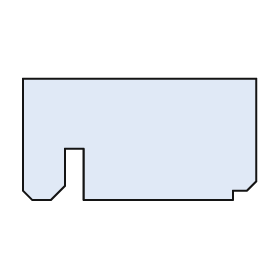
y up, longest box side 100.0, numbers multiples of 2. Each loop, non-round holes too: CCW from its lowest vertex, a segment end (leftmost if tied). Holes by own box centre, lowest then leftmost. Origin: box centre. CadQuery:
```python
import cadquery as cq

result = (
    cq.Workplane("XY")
    .moveTo(-46.0, -26.0)
    .lineTo(-38.0, -26.0)
    .lineTo(-32.0, -20.0)
    .lineTo(-32.0, -4.0)
    .lineTo(-24.0, -4.0)
    .lineTo(-24.0, -26.0)
    .lineTo(40.0, -26.0)
    .lineTo(40.0, -22.0)
    .lineTo(46.0, -22.0)
    .lineTo(50.0, -18.0)
    .lineTo(50.0, 26.0)
    .lineTo(-50.0, 26.0)
    .lineTo(-50.0, -22.0)
    .close()
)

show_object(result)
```